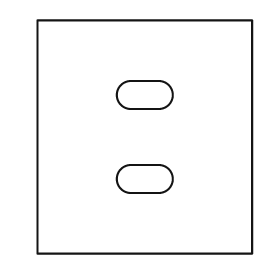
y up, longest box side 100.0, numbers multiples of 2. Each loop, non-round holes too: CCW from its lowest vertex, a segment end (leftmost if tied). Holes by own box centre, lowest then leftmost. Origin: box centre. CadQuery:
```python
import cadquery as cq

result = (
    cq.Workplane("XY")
    .moveTo(-46.0, -50.0)
    .lineTo(46.0, -50.0)
    .lineTo(46.0, 50.0)
    .lineTo(-46.0, 50.0)
    .close()
    .moveTo(-6.0, -24.0)
    .lineTo(6.0, -24.0)
    .threePointArc((12.0, -18.0), (6.0, -12.0))
    .lineTo(-6.0, -12.0)
    .threePointArc((-12.0, -18.0), (-6.0, -24.0))
    .close()
    .moveTo(-6.0, 12.0)
    .lineTo(6.0, 12.0)
    .threePointArc((12.0, 18.0), (6.0, 24.0))
    .lineTo(-6.0, 24.0)
    .threePointArc((-12.0, 18.0), (-6.0, 12.0))
    .close()
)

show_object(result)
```